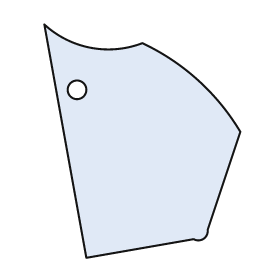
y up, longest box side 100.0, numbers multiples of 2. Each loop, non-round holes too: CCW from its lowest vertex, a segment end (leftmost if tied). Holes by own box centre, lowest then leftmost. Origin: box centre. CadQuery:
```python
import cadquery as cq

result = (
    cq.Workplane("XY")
    .moveTo(-24.0, -50.0)
    .lineTo(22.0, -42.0)
    .threePointArc((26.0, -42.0), (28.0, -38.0))
    .lineTo(42.0, 4.0)
    .threePointArc((24.0, 26.0), (0.0, 42.0))
    .threePointArc((-22.0, 40.0), (-42.0, 50.0))
    .close()
    .moveTo(-28.0, 22.0)
    .circle(4.0)
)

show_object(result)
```